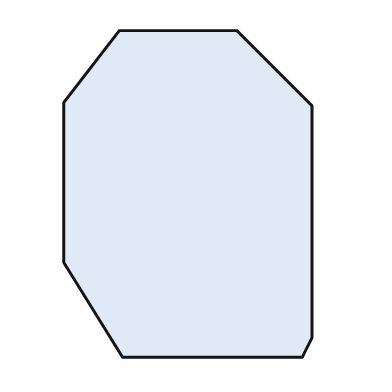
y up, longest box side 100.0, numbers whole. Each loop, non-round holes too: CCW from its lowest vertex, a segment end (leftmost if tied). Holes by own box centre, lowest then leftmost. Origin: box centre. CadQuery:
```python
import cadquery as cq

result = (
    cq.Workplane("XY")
    .moveTo(-20.0, -50.0)
    .lineTo(35.0, -50.0)
    .lineTo(38.0, -44.0)
    .lineTo(38.0, 27.0)
    .lineTo(15.0, 50.0)
    .lineTo(-21.0, 50.0)
    .lineTo(-38.0, 28.0)
    .lineTo(-38.0, -21.0)
    .close()
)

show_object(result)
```